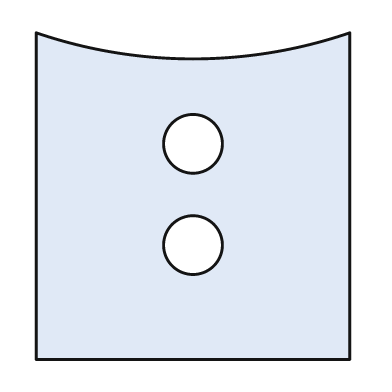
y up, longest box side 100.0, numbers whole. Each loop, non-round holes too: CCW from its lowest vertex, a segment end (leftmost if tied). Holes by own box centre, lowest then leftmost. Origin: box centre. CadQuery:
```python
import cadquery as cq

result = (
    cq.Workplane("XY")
    .moveTo(-48.0, -50.0)
    .lineTo(48.0, -50.0)
    .lineTo(48.0, 50.0)
    .threePointArc((0.0, 42.0), (-48.0, 50.0))
    .close()
    .moveTo(0.0, -15.0)
    .circle(9.0)
    .moveTo(0.0, 16.0)
    .circle(9.0)
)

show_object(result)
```